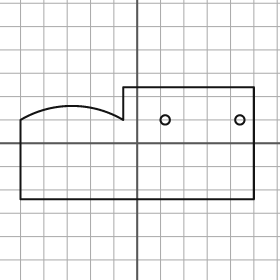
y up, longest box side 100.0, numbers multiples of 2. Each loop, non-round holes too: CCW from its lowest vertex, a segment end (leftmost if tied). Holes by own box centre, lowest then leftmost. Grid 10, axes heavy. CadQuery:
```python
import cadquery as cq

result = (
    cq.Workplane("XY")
    .moveTo(-50.0, -24.0)
    .lineTo(50.0, -24.0)
    .lineTo(50.0, 24.0)
    .lineTo(-6.0, 24.0)
    .lineTo(-6.0, 10.0)
    .threePointArc((-28.0, 16.0), (-50.0, 10.0))
    .close()
    .moveTo(12.0, 10.0)
    .circle(2.0)
    .moveTo(44.0, 10.0)
    .circle(2.0)
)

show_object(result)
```